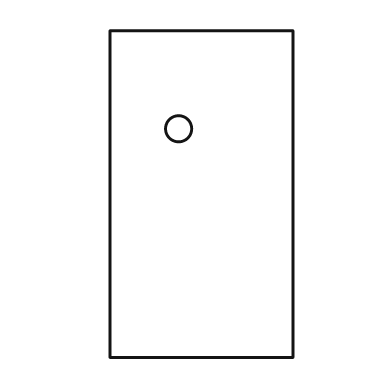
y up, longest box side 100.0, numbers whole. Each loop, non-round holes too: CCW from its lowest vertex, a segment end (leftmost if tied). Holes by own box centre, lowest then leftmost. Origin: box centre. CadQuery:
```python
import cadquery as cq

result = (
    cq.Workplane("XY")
    .moveTo(-28.0, -50.0)
    .lineTo(28.0, -50.0)
    .lineTo(28.0, 50.0)
    .lineTo(-28.0, 50.0)
    .close()
    .moveTo(-7.0, 20.0)
    .circle(4.0)
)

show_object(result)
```